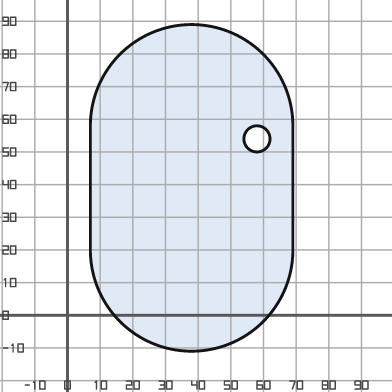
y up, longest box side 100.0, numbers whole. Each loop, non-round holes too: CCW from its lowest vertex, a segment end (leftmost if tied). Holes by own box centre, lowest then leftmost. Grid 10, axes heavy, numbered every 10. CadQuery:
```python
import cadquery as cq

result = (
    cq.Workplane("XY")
    .moveTo(7.0, 20.0)
    .threePointArc((38.0, -11.0), (69.0, 20.0))
    .lineTo(69.0, 58.0)
    .threePointArc((38.0, 89.0), (7.0, 58.0))
    .close()
    .moveTo(58.0, 54.0)
    .circle(4.0)
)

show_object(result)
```